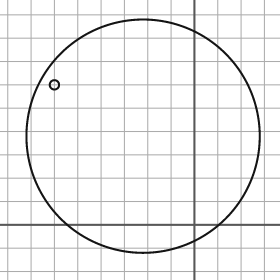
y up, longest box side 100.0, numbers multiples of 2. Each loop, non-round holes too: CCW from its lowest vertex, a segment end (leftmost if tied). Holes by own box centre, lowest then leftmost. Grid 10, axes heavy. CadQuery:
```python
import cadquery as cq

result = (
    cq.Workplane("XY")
    .moveTo(-22.0, 38.0)
    .circle(50.0)
    .moveTo(-60.0, 60.0)
    .circle(2.0)
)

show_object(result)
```